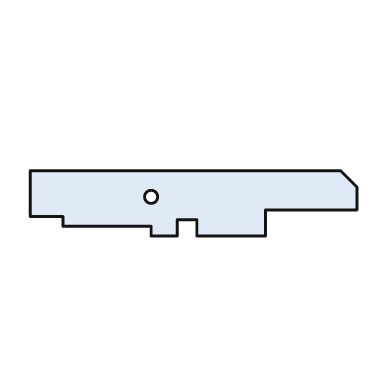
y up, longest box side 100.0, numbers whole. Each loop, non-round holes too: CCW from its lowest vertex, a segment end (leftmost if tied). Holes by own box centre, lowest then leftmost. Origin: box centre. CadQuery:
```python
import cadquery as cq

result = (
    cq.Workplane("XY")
    .moveTo(-13.0, -10.0)
    .lineTo(-5.0, -10.0)
    .lineTo(-5.0, -5.0)
    .lineTo(1.0, -5.0)
    .lineTo(1.0, -10.0)
    .lineTo(22.0, -10.0)
    .lineTo(22.0, -2.0)
    .lineTo(50.0, -2.0)
    .lineTo(50.0, 5.0)
    .lineTo(45.0, 10.0)
    .lineTo(-50.0, 10.0)
    .lineTo(-50.0, -4.0)
    .lineTo(-40.0, -4.0)
    .lineTo(-40.0, -7.0)
    .lineTo(-13.0, -7.0)
    .close()
    .moveTo(-13.0, 2.0)
    .circle(2.0)
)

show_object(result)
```